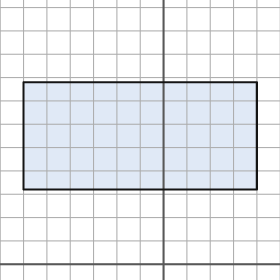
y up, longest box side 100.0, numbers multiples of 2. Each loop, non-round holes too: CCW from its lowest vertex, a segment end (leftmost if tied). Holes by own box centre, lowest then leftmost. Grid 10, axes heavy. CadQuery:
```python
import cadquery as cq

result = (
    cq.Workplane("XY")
    .moveTo(-60.0, 32.0)
    .lineTo(40.0, 32.0)
    .lineTo(40.0, 78.0)
    .lineTo(-60.0, 78.0)
    .close()
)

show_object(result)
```